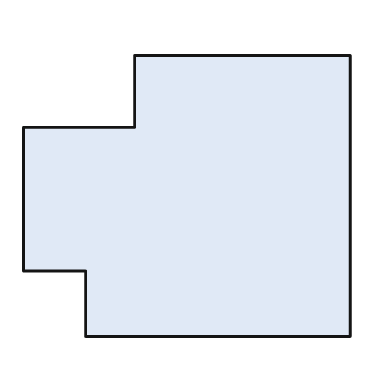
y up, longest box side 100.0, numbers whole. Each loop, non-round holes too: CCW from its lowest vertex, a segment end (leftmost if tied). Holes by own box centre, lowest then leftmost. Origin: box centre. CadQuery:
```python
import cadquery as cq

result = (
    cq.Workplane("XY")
    .moveTo(-31.0, -43.0)
    .lineTo(50.0, -43.0)
    .lineTo(50.0, 43.0)
    .lineTo(-16.0, 43.0)
    .lineTo(-16.0, 21.0)
    .lineTo(-50.0, 21.0)
    .lineTo(-50.0, -23.0)
    .lineTo(-31.0, -23.0)
    .close()
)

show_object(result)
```